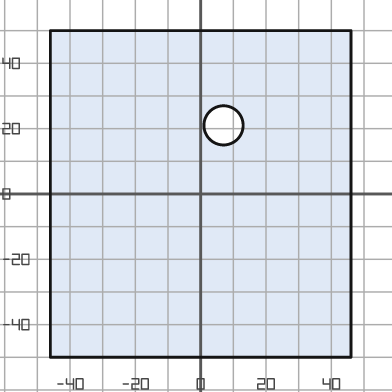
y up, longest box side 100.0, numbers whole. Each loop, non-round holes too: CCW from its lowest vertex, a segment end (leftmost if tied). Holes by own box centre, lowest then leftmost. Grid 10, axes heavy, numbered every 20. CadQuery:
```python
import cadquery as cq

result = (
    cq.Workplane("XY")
    .moveTo(-46.0, -50.0)
    .lineTo(46.0, -50.0)
    .lineTo(46.0, 50.0)
    .lineTo(-46.0, 50.0)
    .close()
    .moveTo(7.0, 21.0)
    .circle(6.0)
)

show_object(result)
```